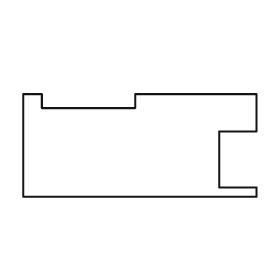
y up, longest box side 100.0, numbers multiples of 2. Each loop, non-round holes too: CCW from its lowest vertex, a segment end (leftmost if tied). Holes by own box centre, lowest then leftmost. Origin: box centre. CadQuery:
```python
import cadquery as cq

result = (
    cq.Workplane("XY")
    .moveTo(-50.0, -22.0)
    .lineTo(50.0, -22.0)
    .lineTo(50.0, -18.0)
    .lineTo(34.0, -18.0)
    .lineTo(34.0, 6.0)
    .lineTo(50.0, 6.0)
    .lineTo(50.0, 22.0)
    .lineTo(-2.0, 22.0)
    .lineTo(-2.0, 16.0)
    .lineTo(-42.0, 16.0)
    .lineTo(-42.0, 22.0)
    .lineTo(-50.0, 22.0)
    .close()
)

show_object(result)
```